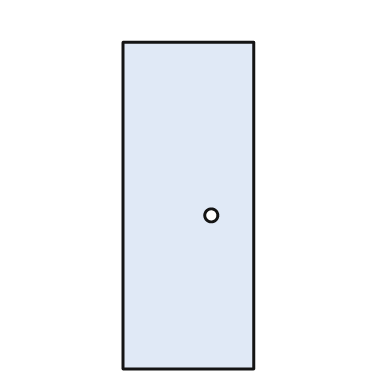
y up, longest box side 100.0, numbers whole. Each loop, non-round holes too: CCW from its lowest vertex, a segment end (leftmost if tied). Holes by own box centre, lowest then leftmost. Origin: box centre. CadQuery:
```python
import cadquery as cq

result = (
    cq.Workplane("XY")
    .moveTo(-20.0, -50.0)
    .lineTo(20.0, -50.0)
    .lineTo(20.0, 50.0)
    .lineTo(-20.0, 50.0)
    .close()
    .moveTo(7.0, -3.0)
    .circle(2.0)
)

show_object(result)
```